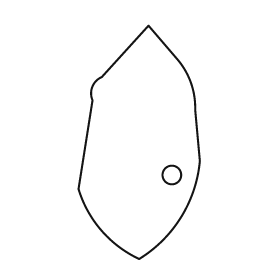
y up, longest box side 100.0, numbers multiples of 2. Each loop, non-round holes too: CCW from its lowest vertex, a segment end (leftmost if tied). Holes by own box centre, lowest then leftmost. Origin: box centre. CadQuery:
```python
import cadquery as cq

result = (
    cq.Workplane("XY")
    .moveTo(0.0, -50.0)
    .threePointArc((18.0, -32.0), (26.0, -8.0))
    .lineTo(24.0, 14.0)
    .threePointArc((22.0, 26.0), (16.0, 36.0))
    .lineTo(4.0, 50.0)
    .lineTo(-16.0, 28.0)
    .threePointArc((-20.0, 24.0), (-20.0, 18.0))
    .lineTo(-26.0, -20.0)
    .threePointArc((-16.0, -38.0), (0.0, -50.0))
    .close()
    .moveTo(14.0, -14.0)
    .circle(4.0)
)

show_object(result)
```